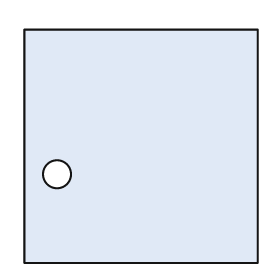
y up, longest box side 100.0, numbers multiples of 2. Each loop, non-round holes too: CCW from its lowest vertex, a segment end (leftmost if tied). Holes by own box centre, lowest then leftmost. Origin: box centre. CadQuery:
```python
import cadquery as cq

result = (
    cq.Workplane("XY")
    .moveTo(-50.0, -50.0)
    .lineTo(50.0, -50.0)
    .lineTo(50.0, 50.0)
    .lineTo(-50.0, 50.0)
    .close()
    .moveTo(-36.0, -12.0)
    .circle(6.0)
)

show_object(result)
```